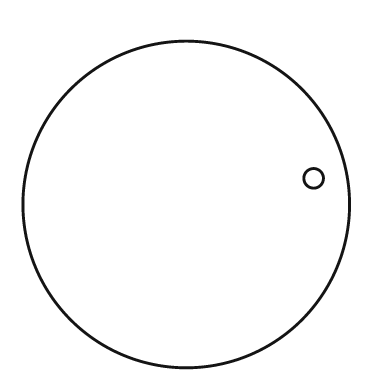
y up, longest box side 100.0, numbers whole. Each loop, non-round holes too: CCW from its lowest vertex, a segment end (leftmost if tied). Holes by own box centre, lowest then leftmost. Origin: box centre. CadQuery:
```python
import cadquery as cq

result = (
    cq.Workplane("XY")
    .moveTo(0.0, 0.0)
    .circle(50.0)
    .moveTo(39.0, 8.0)
    .circle(3.0)
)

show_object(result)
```